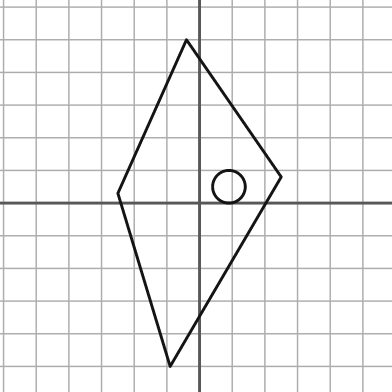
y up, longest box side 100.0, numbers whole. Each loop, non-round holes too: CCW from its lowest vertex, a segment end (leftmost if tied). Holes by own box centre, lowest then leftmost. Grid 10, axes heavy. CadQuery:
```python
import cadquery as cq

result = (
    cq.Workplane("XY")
    .moveTo(-9.0, -50.0)
    .lineTo(25.0, 8.0)
    .lineTo(-4.0, 50.0)
    .lineTo(-25.0, 3.0)
    .close()
    .moveTo(9.0, 5.0)
    .circle(5.0)
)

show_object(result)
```